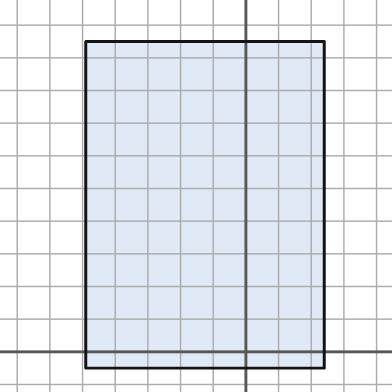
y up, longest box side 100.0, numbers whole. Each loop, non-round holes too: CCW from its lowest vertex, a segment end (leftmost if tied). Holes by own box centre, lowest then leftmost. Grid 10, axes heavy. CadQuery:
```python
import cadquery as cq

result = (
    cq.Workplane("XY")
    .moveTo(-49.0, -5.0)
    .lineTo(24.0, -5.0)
    .lineTo(24.0, 95.0)
    .lineTo(-49.0, 95.0)
    .close()
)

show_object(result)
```